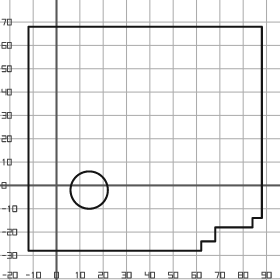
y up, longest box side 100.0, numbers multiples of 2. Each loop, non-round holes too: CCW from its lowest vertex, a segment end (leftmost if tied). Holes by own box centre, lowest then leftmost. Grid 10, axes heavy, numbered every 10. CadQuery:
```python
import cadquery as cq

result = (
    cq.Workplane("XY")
    .moveTo(-12.0, -28.0)
    .lineTo(62.0, -28.0)
    .lineTo(62.0, -24.0)
    .lineTo(68.0, -24.0)
    .lineTo(68.0, -18.0)
    .lineTo(84.0, -18.0)
    .lineTo(84.0, -14.0)
    .lineTo(88.0, -14.0)
    .lineTo(88.0, 68.0)
    .lineTo(-12.0, 68.0)
    .close()
    .moveTo(14.0, -2.0)
    .circle(8.0)
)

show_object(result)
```